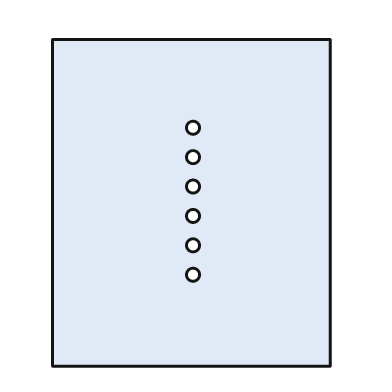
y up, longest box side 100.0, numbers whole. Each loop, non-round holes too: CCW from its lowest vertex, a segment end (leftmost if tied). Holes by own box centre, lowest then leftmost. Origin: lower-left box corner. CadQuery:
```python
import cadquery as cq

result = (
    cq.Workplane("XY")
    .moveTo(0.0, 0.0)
    .lineTo(85.0, 0.0)
    .lineTo(85.0, 100.0)
    .lineTo(0.0, 100.0)
    .close()
    .moveTo(43.0, 28.0)
    .circle(2.0)
    .moveTo(43.0, 37.0)
    .circle(2.0)
    .moveTo(43.0, 46.0)
    .circle(2.0)
    .moveTo(43.0, 55.0)
    .circle(2.0)
    .moveTo(43.0, 64.0)
    .circle(2.0)
    .moveTo(43.0, 73.0)
    .circle(2.0)
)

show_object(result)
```